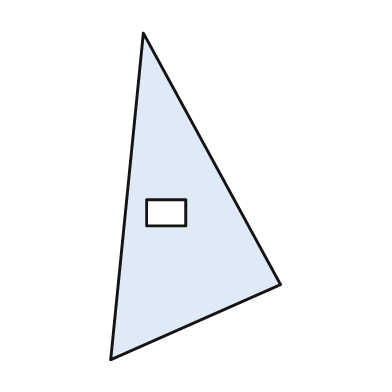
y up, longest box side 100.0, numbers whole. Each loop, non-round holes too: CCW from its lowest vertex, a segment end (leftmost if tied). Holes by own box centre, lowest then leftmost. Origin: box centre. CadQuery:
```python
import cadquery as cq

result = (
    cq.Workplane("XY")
    .moveTo(-26.0, -50.0)
    .lineTo(26.0, -27.0)
    .lineTo(-16.0, 50.0)
    .close()
    .moveTo(-15.0, -9.0)
    .lineTo(-3.0, -9.0)
    .lineTo(-3.0, -1.0)
    .lineTo(-15.0, -1.0)
    .close()
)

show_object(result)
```